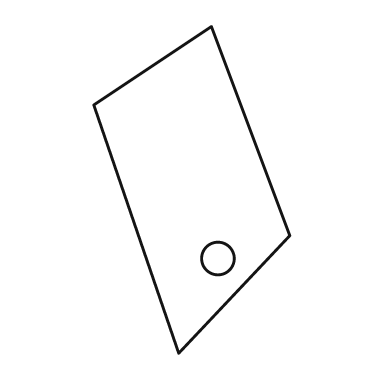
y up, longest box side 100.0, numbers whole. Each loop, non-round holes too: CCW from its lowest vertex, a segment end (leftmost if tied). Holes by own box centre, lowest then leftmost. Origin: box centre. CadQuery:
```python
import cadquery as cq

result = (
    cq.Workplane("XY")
    .moveTo(-4.0, -50.0)
    .lineTo(30.0, -14.0)
    .lineTo(6.0, 50.0)
    .lineTo(-30.0, 26.0)
    .close()
    .moveTo(8.0, -21.0)
    .circle(5.0)
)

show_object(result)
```